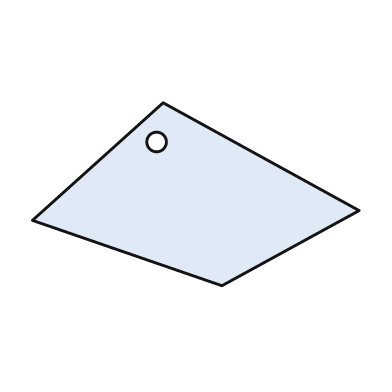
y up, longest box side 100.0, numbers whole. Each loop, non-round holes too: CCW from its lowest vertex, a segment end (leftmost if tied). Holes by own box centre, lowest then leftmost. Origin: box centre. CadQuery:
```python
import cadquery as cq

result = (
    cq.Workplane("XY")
    .moveTo(8.0, -28.0)
    .lineTo(50.0, -5.0)
    .lineTo(-10.0, 28.0)
    .lineTo(-50.0, -8.0)
    .close()
    .moveTo(-12.0, 16.0)
    .circle(3.0)
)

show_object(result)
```